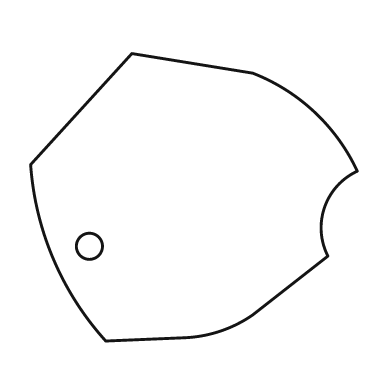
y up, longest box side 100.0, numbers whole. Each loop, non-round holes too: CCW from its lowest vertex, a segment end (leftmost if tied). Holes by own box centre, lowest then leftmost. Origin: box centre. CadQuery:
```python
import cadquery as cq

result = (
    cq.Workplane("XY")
    .moveTo(-27.0, -44.0)
    .lineTo(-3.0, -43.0)
    .threePointArc((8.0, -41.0), (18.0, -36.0))
    .lineTo(41.0, -18.0)
    .threePointArc((40.0, -3.0), (50.0, 8.0))
    .threePointArc((37.0, 26.0), (18.0, 38.0))
    .lineTo(-19.0, 44.0)
    .lineTo(-50.0, 10.0)
    .threePointArc((-43.0, -19.0), (-27.0, -44.0))
    .close()
    .moveTo(-32.0, -15.0)
    .circle(4.0)
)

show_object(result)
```